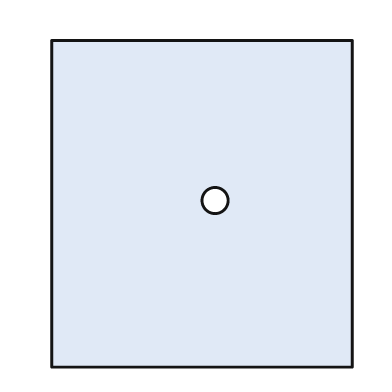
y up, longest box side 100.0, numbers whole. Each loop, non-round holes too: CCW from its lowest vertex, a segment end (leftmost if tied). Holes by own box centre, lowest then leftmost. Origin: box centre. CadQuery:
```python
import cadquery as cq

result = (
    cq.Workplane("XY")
    .moveTo(-46.0, -50.0)
    .lineTo(46.0, -50.0)
    .lineTo(46.0, 50.0)
    .lineTo(-46.0, 50.0)
    .close()
    .moveTo(4.0, 1.0)
    .circle(4.0)
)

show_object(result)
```